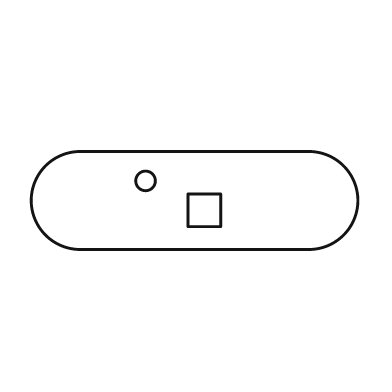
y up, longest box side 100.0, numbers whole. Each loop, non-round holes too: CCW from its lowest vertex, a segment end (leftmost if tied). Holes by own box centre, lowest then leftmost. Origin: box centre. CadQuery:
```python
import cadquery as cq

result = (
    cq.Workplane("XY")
    .moveTo(-35.0, -15.0)
    .lineTo(35.0, -15.0)
    .threePointArc((50.0, 0.0), (35.0, 15.0))
    .lineTo(-35.0, 15.0)
    .threePointArc((-50.0, 0.0), (-35.0, -15.0))
    .close()
    .moveTo(-2.0, -8.0)
    .lineTo(8.0, -8.0)
    .lineTo(8.0, 2.0)
    .lineTo(-2.0, 2.0)
    .close()
    .moveTo(-15.0, 6.0)
    .circle(3.0)
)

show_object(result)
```